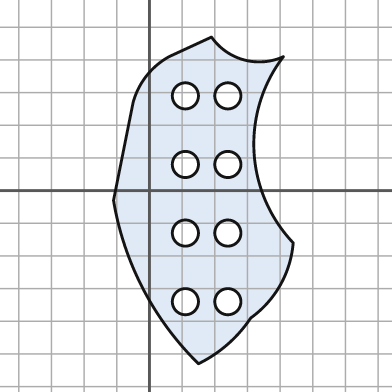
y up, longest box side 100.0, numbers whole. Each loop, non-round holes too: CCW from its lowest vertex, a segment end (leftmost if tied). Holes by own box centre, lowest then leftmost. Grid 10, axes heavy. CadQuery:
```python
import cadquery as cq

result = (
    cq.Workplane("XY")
    .moveTo(15.0, -53.0)
    .threePointArc((24.0, -47.0), (31.0, -39.0))
    .threePointArc((40.0, -29.0), (44.0, -16.0))
    .threePointArc((32.0, 12.0), (41.0, 41.0))
    .threePointArc((29.0, 40.0), (19.0, 47.0))
    .lineTo(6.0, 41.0)
    .threePointArc((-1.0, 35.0), (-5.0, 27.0))
    .lineTo(-11.0, -3.0)
    .threePointArc((-2.0, -30.0), (15.0, -53.0))
    .close()
    .moveTo(11.0, -34.0)
    .circle(4.0)
    .moveTo(24.0, -34.0)
    .circle(4.0)
    .moveTo(11.0, -13.0)
    .circle(4.0)
    .moveTo(24.0, -13.0)
    .circle(4.0)
    .moveTo(11.0, 8.0)
    .circle(4.0)
    .moveTo(24.0, 8.0)
    .circle(4.0)
    .moveTo(11.0, 29.0)
    .circle(4.0)
    .moveTo(24.0, 29.0)
    .circle(4.0)
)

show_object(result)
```